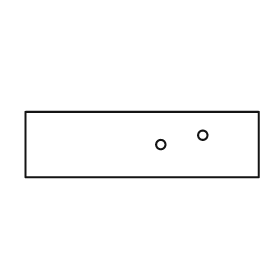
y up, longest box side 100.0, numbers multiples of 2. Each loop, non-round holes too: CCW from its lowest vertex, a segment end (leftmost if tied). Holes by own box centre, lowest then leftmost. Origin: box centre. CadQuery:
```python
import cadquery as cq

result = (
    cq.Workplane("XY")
    .moveTo(-50.0, -14.0)
    .lineTo(50.0, -14.0)
    .lineTo(50.0, 14.0)
    .lineTo(-50.0, 14.0)
    .close()
    .moveTo(8.0, 0.0)
    .circle(2.0)
    .moveTo(26.0, 4.0)
    .circle(2.0)
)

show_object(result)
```